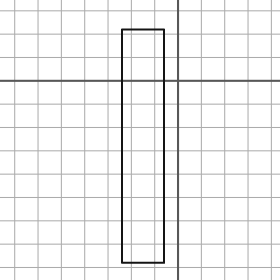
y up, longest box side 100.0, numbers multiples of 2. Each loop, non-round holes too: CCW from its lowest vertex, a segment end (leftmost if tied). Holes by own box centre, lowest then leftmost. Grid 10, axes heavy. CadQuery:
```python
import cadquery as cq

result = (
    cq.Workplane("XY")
    .moveTo(-24.0, -78.0)
    .lineTo(-6.0, -78.0)
    .lineTo(-6.0, 22.0)
    .lineTo(-24.0, 22.0)
    .close()
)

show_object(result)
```